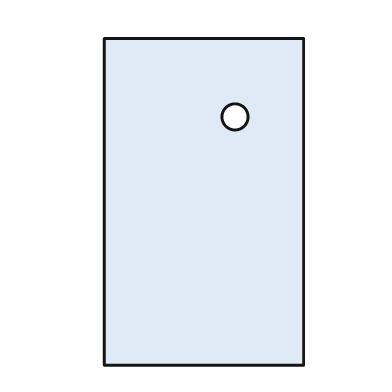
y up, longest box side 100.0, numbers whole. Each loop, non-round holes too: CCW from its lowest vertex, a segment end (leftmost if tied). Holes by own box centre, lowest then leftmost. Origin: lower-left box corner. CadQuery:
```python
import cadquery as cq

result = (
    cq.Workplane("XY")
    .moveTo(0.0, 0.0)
    .lineTo(61.0, 0.0)
    .lineTo(61.0, 100.0)
    .lineTo(0.0, 100.0)
    .close()
    .moveTo(40.0, 76.0)
    .circle(4.0)
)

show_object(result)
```